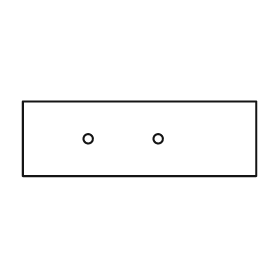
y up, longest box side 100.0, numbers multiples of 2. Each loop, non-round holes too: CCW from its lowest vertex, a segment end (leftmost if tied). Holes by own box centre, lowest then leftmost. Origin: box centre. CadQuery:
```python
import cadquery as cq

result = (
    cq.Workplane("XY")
    .moveTo(-50.0, -16.0)
    .lineTo(50.0, -16.0)
    .lineTo(50.0, 16.0)
    .lineTo(-50.0, 16.0)
    .close()
    .moveTo(-22.0, 0.0)
    .circle(2.0)
    .moveTo(8.0, 0.0)
    .circle(2.0)
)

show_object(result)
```